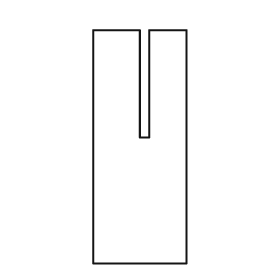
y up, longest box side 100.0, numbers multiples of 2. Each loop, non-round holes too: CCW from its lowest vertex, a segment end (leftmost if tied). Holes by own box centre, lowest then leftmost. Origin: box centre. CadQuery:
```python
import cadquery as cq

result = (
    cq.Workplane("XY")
    .moveTo(-20.0, -50.0)
    .lineTo(20.0, -50.0)
    .lineTo(20.0, 50.0)
    .lineTo(4.0, 50.0)
    .lineTo(4.0, 4.0)
    .lineTo(0.0, 4.0)
    .lineTo(0.0, 50.0)
    .lineTo(-20.0, 50.0)
    .close()
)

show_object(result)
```